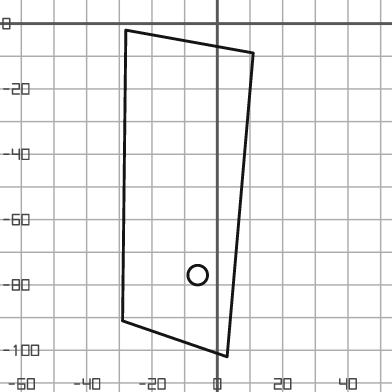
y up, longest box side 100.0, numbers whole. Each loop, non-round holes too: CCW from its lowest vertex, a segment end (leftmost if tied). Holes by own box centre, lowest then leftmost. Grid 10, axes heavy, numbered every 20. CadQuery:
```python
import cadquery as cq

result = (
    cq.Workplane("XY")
    .moveTo(3.0, -102.0)
    .lineTo(11.0, -9.0)
    .lineTo(-28.0, -2.0)
    .lineTo(-29.0, -91.0)
    .close()
    .moveTo(-6.0, -77.0)
    .circle(3.0)
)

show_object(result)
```